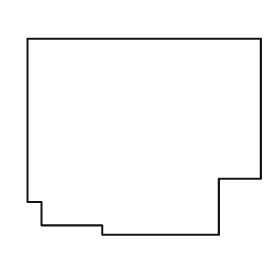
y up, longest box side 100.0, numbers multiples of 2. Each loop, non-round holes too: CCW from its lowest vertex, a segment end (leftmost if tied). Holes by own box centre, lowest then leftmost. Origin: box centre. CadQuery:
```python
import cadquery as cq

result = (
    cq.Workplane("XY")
    .moveTo(-18.0, -42.0)
    .lineTo(32.0, -42.0)
    .lineTo(32.0, -18.0)
    .lineTo(50.0, -18.0)
    .lineTo(50.0, 42.0)
    .lineTo(-50.0, 42.0)
    .lineTo(-50.0, -28.0)
    .lineTo(-44.0, -28.0)
    .lineTo(-44.0, -38.0)
    .lineTo(-18.0, -38.0)
    .close()
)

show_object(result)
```